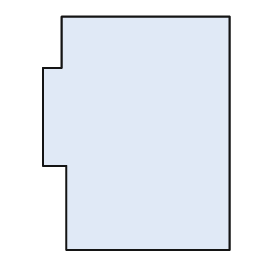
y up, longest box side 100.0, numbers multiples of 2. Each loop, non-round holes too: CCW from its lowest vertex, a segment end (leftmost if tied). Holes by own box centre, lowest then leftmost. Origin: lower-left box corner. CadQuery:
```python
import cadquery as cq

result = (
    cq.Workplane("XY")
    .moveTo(10.0, 0.0)
    .lineTo(80.0, 0.0)
    .lineTo(80.0, 100.0)
    .lineTo(8.0, 100.0)
    .lineTo(8.0, 78.0)
    .lineTo(0.0, 78.0)
    .lineTo(0.0, 36.0)
    .lineTo(10.0, 36.0)
    .close()
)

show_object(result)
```